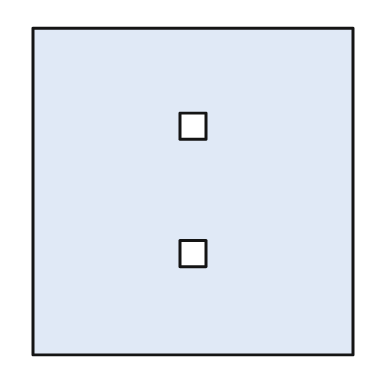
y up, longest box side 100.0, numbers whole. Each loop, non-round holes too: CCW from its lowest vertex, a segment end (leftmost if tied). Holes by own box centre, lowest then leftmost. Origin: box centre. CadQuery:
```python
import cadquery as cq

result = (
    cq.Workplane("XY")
    .moveTo(-49.0, -50.0)
    .lineTo(49.0, -50.0)
    .lineTo(49.0, 50.0)
    .lineTo(-49.0, 50.0)
    .close()
    .moveTo(-4.0, -23.0)
    .lineTo(4.0, -23.0)
    .lineTo(4.0, -15.0)
    .lineTo(-4.0, -15.0)
    .close()
    .moveTo(-4.0, 16.0)
    .lineTo(4.0, 16.0)
    .lineTo(4.0, 24.0)
    .lineTo(-4.0, 24.0)
    .close()
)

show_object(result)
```